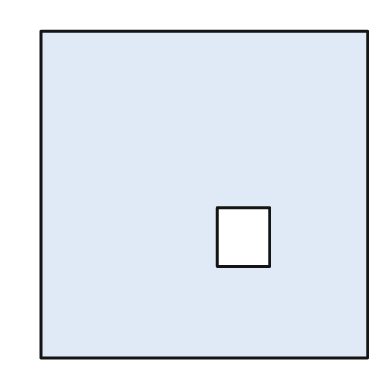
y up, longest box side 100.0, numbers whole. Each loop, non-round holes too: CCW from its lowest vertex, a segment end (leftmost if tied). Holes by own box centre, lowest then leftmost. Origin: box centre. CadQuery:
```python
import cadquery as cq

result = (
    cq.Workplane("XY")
    .moveTo(-50.0, -50.0)
    .lineTo(50.0, -50.0)
    .lineTo(50.0, 50.0)
    .lineTo(-50.0, 50.0)
    .close()
    .moveTo(4.0, -22.0)
    .lineTo(20.0, -22.0)
    .lineTo(20.0, -4.0)
    .lineTo(4.0, -4.0)
    .close()
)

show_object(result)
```